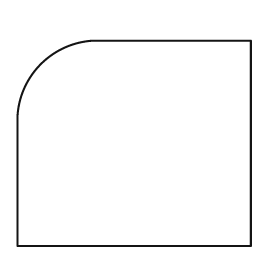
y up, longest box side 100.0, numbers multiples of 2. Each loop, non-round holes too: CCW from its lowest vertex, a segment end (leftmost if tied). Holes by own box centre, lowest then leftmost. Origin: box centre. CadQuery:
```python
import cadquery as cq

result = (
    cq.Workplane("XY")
    .moveTo(-50.0, -44.0)
    .lineTo(50.0, -44.0)
    .lineTo(50.0, 44.0)
    .lineTo(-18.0, 44.0)
    .threePointArc((-40.0, 34.0), (-50.0, 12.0))
    .close()
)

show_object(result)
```